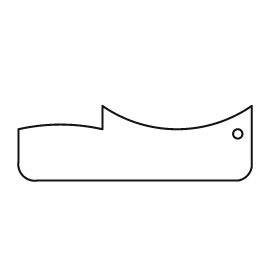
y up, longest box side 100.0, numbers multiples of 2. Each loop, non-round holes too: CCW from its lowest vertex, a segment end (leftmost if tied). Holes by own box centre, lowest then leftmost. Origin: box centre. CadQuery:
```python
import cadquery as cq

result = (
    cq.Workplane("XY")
    .moveTo(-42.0, -16.0)
    .lineTo(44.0, -16.0)
    .threePointArc((48.0, -14.0), (50.0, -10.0))
    .lineTo(50.0, 16.0)
    .threePointArc((18.0, 6.0), (-14.0, 16.0))
    .lineTo(-14.0, 6.0)
    .threePointArc((-32.0, 8.0), (-50.0, 6.0))
    .lineTo(-50.0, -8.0)
    .threePointArc((-48.0, -14.0), (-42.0, -16.0))
    .close()
    .moveTo(44.0, 4.0)
    .circle(2.0)
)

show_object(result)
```